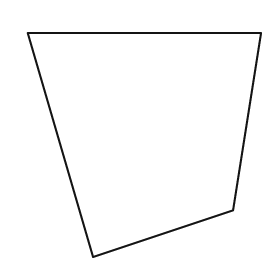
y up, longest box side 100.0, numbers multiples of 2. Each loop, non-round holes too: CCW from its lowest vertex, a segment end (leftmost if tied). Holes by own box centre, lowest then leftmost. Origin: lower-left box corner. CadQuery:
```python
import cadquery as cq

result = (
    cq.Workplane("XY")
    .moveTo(28.0, 0.0)
    .lineTo(88.0, 20.0)
    .lineTo(100.0, 96.0)
    .lineTo(0.0, 96.0)
    .close()
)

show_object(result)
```